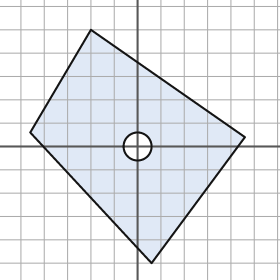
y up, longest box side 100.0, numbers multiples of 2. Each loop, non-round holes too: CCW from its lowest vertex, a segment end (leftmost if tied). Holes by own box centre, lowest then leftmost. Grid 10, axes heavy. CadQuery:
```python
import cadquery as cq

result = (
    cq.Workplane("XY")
    .moveTo(6.0, -50.0)
    .lineTo(46.0, 4.0)
    .lineTo(-20.0, 50.0)
    .lineTo(-46.0, 6.0)
    .close()
    .moveTo(0.0, 0.0)
    .circle(6.0)
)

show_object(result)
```